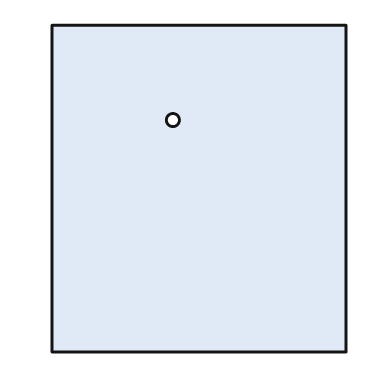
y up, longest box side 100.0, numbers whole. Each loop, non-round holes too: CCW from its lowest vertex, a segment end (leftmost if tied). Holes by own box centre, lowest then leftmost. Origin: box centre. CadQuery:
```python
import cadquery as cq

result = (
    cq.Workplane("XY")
    .moveTo(-45.0, -50.0)
    .lineTo(45.0, -50.0)
    .lineTo(45.0, 50.0)
    .lineTo(-45.0, 50.0)
    .close()
    .moveTo(-8.0, 21.0)
    .circle(2.0)
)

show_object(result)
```